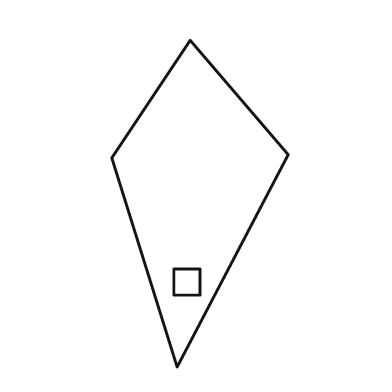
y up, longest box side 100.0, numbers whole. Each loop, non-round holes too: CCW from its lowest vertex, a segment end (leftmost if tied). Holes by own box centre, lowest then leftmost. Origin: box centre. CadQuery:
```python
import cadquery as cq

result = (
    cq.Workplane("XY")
    .moveTo(-7.0, -50.0)
    .lineTo(27.0, 15.0)
    .lineTo(-3.0, 50.0)
    .lineTo(-27.0, 14.0)
    .close()
    .moveTo(-8.0, -28.0)
    .lineTo(0.0, -28.0)
    .lineTo(0.0, -20.0)
    .lineTo(-8.0, -20.0)
    .close()
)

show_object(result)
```